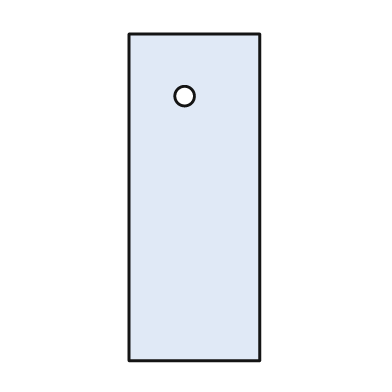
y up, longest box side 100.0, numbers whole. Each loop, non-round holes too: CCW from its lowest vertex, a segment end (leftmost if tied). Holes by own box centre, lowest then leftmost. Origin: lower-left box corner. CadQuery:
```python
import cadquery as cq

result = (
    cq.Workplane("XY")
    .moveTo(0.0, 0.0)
    .lineTo(40.0, 0.0)
    .lineTo(40.0, 100.0)
    .lineTo(0.0, 100.0)
    .close()
    .moveTo(17.0, 81.0)
    .circle(3.0)
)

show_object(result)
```